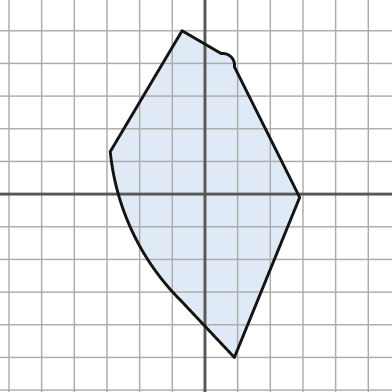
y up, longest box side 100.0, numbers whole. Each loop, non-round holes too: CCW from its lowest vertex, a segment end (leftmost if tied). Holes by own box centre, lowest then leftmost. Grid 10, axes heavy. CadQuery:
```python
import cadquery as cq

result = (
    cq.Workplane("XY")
    .moveTo(9.0, -50.0)
    .lineTo(29.0, -1.0)
    .lineTo(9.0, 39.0)
    .threePointArc((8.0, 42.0), (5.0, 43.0))
    .lineTo(-7.0, 50.0)
    .lineTo(-29.0, 13.0)
    .threePointArc((-22.0, -12.0), (-7.0, -33.0))
    .close()
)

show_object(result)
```